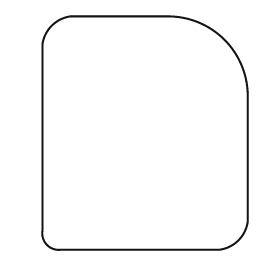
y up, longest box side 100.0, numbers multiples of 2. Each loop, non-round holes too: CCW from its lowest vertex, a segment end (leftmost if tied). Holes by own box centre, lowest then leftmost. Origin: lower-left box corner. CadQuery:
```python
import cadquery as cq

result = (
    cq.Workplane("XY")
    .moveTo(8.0, 0.0)
    .lineTo(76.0, 0.0)
    .threePointArc((84.0, 4.0), (88.0, 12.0))
    .lineTo(88.0, 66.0)
    .threePointArc((78.0, 90.0), (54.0, 100.0))
    .lineTo(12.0, 100.0)
    .threePointArc((4.0, 96.0), (0.0, 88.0))
    .lineTo(0.0, 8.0)
    .threePointArc((2.0, 2.0), (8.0, 0.0))
    .close()
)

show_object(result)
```